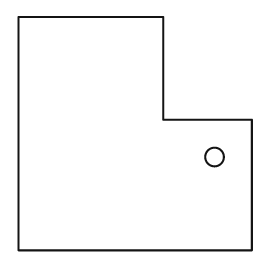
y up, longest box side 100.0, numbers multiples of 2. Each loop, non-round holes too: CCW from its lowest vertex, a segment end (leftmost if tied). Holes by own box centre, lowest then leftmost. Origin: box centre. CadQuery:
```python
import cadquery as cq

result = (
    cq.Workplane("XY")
    .moveTo(-50.0, -50.0)
    .lineTo(50.0, -50.0)
    .lineTo(50.0, 6.0)
    .lineTo(12.0, 6.0)
    .lineTo(12.0, 50.0)
    .lineTo(-50.0, 50.0)
    .close()
    .moveTo(34.0, -10.0)
    .circle(4.0)
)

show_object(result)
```